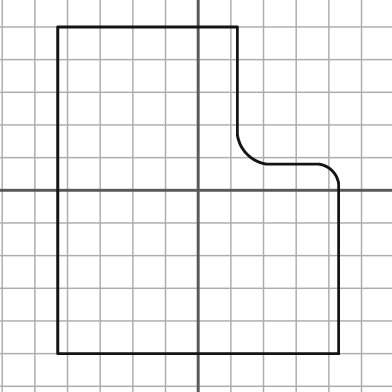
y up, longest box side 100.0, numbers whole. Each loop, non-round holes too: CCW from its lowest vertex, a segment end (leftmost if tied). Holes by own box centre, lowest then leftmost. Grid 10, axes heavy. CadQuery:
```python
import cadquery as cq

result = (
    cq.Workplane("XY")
    .moveTo(-43.0, -50.0)
    .lineTo(43.0, -50.0)
    .lineTo(43.0, 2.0)
    .threePointArc((41.0, 6.0), (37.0, 8.0))
    .lineTo(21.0, 8.0)
    .threePointArc((15.0, 11.0), (12.0, 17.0))
    .lineTo(12.0, 50.0)
    .lineTo(-43.0, 50.0)
    .close()
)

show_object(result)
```